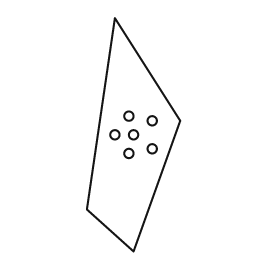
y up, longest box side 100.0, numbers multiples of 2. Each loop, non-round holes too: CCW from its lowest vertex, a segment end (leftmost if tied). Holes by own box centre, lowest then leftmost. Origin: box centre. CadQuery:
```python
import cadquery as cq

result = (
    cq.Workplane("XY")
    .moveTo(0.0, -50.0)
    .lineTo(20.0, 6.0)
    .lineTo(-8.0, 50.0)
    .lineTo(-20.0, -32.0)
    .close()
    .moveTo(-2.0, -8.0)
    .circle(2.0)
    .moveTo(8.0, -6.0)
    .circle(2.0)
    .moveTo(-8.0, 0.0)
    .circle(2.0)
    .moveTo(0.0, 0.0)
    .circle(2.0)
    .moveTo(8.0, 6.0)
    .circle(2.0)
    .moveTo(-2.0, 8.0)
    .circle(2.0)
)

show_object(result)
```